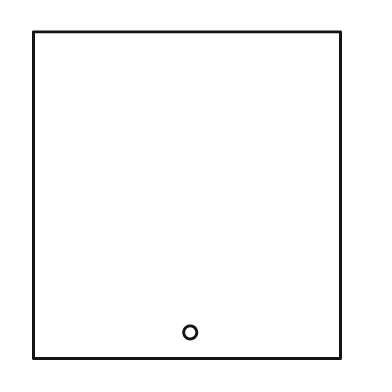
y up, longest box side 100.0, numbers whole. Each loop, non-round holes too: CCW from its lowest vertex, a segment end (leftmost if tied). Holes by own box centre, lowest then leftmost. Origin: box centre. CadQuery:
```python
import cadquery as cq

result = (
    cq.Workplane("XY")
    .moveTo(-47.0, -50.0)
    .lineTo(47.0, -50.0)
    .lineTo(47.0, 50.0)
    .lineTo(-47.0, 50.0)
    .close()
    .moveTo(1.0, -42.0)
    .circle(2.0)
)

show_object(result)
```